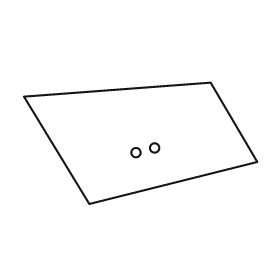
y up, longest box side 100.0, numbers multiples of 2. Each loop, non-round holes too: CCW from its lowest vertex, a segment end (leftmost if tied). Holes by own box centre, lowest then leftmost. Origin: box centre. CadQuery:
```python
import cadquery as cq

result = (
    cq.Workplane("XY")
    .moveTo(-22.0, -26.0)
    .lineTo(50.0, -8.0)
    .lineTo(30.0, 26.0)
    .lineTo(-50.0, 20.0)
    .close()
    .moveTo(-2.0, -4.0)
    .circle(2.0)
    .moveTo(6.0, -2.0)
    .circle(2.0)
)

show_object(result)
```